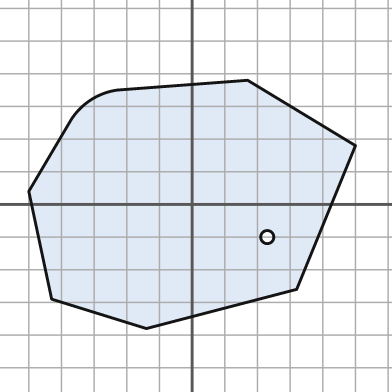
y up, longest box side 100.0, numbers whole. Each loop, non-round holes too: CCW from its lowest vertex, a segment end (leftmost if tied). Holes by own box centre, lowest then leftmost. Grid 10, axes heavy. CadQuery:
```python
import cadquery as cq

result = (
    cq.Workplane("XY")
    .moveTo(-14.0, -38.0)
    .lineTo(32.0, -26.0)
    .lineTo(50.0, 18.0)
    .lineTo(17.0, 38.0)
    .lineTo(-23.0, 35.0)
    .threePointArc((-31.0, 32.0), (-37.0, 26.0))
    .lineTo(-50.0, 4.0)
    .lineTo(-43.0, -29.0)
    .close()
    .moveTo(23.0, -10.0)
    .circle(2.0)
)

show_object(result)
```